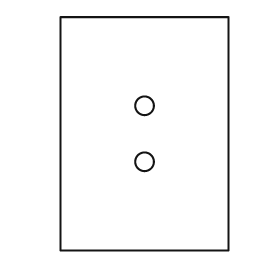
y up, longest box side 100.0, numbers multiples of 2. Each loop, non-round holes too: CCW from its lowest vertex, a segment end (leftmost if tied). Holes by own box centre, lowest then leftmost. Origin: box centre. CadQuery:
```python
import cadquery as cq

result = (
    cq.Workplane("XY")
    .moveTo(-36.0, -50.0)
    .lineTo(36.0, -50.0)
    .lineTo(36.0, 50.0)
    .lineTo(-36.0, 50.0)
    .close()
    .moveTo(0.0, -12.0)
    .circle(4.0)
    .moveTo(0.0, 12.0)
    .circle(4.0)
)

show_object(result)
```